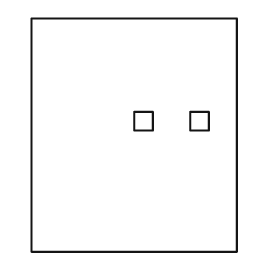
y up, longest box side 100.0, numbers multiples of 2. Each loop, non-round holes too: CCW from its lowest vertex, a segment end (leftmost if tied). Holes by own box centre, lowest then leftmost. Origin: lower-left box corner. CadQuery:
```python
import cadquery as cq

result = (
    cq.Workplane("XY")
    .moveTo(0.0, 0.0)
    .lineTo(88.0, 0.0)
    .lineTo(88.0, 100.0)
    .lineTo(0.0, 100.0)
    .close()
    .moveTo(44.0, 52.0)
    .lineTo(52.0, 52.0)
    .lineTo(52.0, 60.0)
    .lineTo(44.0, 60.0)
    .close()
    .moveTo(68.0, 52.0)
    .lineTo(76.0, 52.0)
    .lineTo(76.0, 60.0)
    .lineTo(68.0, 60.0)
    .close()
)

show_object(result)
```